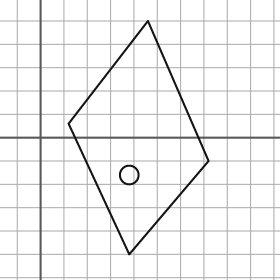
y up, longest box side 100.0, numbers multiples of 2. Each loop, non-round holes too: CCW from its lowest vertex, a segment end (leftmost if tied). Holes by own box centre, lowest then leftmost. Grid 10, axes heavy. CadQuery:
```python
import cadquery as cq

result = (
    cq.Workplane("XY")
    .moveTo(38.0, -50.0)
    .lineTo(72.0, -10.0)
    .lineTo(46.0, 50.0)
    .lineTo(12.0, 6.0)
    .close()
    .moveTo(38.0, -16.0)
    .circle(4.0)
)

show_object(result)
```